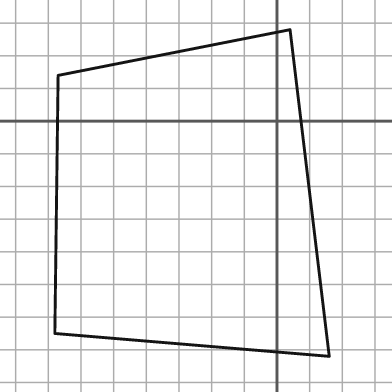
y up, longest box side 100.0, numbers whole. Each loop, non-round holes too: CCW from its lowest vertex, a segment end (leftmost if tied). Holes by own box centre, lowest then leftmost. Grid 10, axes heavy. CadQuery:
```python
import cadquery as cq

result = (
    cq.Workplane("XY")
    .moveTo(16.0, -72.0)
    .lineTo(4.0, 28.0)
    .lineTo(-67.0, 14.0)
    .lineTo(-68.0, -65.0)
    .close()
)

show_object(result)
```